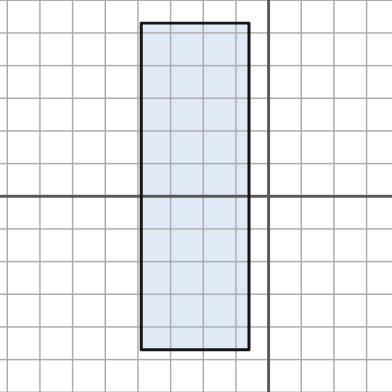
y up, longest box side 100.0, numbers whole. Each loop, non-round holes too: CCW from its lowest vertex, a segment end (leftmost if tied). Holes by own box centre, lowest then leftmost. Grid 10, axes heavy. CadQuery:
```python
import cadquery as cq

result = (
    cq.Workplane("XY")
    .moveTo(-39.0, -47.0)
    .lineTo(-6.0, -47.0)
    .lineTo(-6.0, 53.0)
    .lineTo(-39.0, 53.0)
    .close()
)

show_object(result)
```